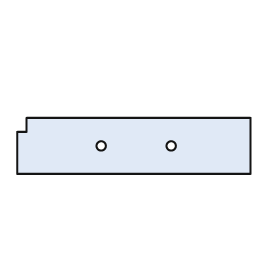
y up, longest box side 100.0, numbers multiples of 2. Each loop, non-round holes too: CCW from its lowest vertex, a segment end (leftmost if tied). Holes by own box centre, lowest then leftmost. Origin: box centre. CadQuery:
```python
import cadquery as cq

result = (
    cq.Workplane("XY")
    .moveTo(-50.0, -12.0)
    .lineTo(50.0, -12.0)
    .lineTo(50.0, 12.0)
    .lineTo(-46.0, 12.0)
    .lineTo(-46.0, 6.0)
    .lineTo(-50.0, 6.0)
    .close()
    .moveTo(-14.0, 0.0)
    .circle(2.0)
    .moveTo(16.0, 0.0)
    .circle(2.0)
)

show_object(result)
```